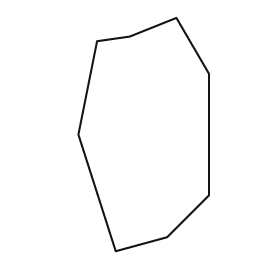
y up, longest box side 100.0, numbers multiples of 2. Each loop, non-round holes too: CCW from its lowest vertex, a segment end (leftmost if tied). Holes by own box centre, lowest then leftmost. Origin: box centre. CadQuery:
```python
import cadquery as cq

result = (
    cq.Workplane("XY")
    .moveTo(-12.0, -50.0)
    .lineTo(10.0, -44.0)
    .lineTo(28.0, -26.0)
    .lineTo(28.0, 26.0)
    .lineTo(14.0, 50.0)
    .lineTo(-6.0, 42.0)
    .lineTo(-20.0, 40.0)
    .lineTo(-28.0, 0.0)
    .close()
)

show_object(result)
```